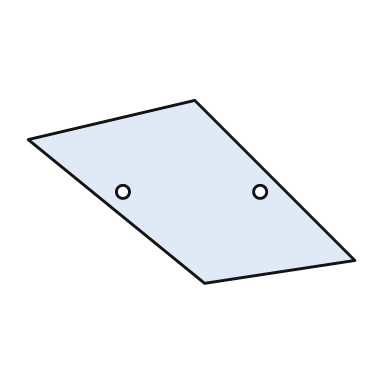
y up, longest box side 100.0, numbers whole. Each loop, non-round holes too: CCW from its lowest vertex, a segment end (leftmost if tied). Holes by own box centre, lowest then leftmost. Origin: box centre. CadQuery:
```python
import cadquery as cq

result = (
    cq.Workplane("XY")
    .moveTo(4.0, -28.0)
    .lineTo(50.0, -21.0)
    .lineTo(1.0, 28.0)
    .lineTo(-50.0, 16.0)
    .close()
    .moveTo(-21.0, 0.0)
    .circle(2.0)
    .moveTo(21.0, 0.0)
    .circle(2.0)
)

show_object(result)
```